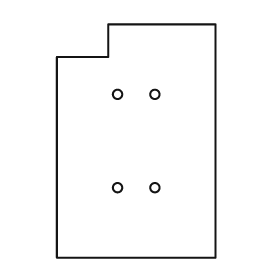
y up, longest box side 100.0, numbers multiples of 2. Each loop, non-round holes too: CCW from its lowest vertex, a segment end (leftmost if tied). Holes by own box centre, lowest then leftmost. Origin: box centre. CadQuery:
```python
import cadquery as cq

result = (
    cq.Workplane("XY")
    .moveTo(-34.0, -50.0)
    .lineTo(34.0, -50.0)
    .lineTo(34.0, 50.0)
    .lineTo(-12.0, 50.0)
    .lineTo(-12.0, 36.0)
    .lineTo(-34.0, 36.0)
    .close()
    .moveTo(-8.0, -20.0)
    .circle(2.0)
    .moveTo(8.0, -20.0)
    .circle(2.0)
    .moveTo(-8.0, 20.0)
    .circle(2.0)
    .moveTo(8.0, 20.0)
    .circle(2.0)
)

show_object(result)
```